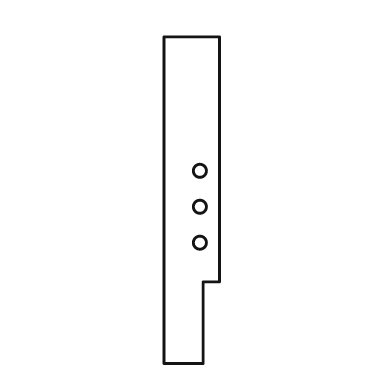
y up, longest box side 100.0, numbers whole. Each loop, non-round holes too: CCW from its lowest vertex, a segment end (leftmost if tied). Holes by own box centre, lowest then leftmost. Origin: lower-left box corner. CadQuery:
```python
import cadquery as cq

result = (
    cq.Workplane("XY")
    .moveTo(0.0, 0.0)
    .lineTo(12.0, 0.0)
    .lineTo(12.0, 25.0)
    .lineTo(17.0, 25.0)
    .lineTo(17.0, 100.0)
    .lineTo(0.0, 100.0)
    .close()
    .moveTo(11.0, 37.0)
    .circle(2.0)
    .moveTo(11.0, 48.0)
    .circle(2.0)
    .moveTo(11.0, 59.0)
    .circle(2.0)
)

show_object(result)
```